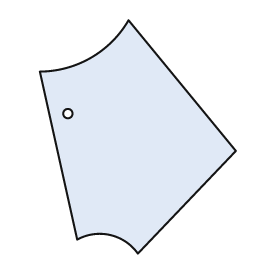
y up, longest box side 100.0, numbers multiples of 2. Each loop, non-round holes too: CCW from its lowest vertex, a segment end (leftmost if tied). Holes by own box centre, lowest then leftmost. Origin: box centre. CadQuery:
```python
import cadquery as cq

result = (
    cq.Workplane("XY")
    .moveTo(0.0, -50.0)
    .lineTo(42.0, -6.0)
    .lineTo(-4.0, 50.0)
    .threePointArc((-20.0, 34.0), (-42.0, 28.0))
    .lineTo(-26.0, -44.0)
    .threePointArc((-12.0, -42.0), (0.0, -50.0))
    .close()
    .moveTo(-30.0, 10.0)
    .circle(2.0)
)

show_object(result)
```